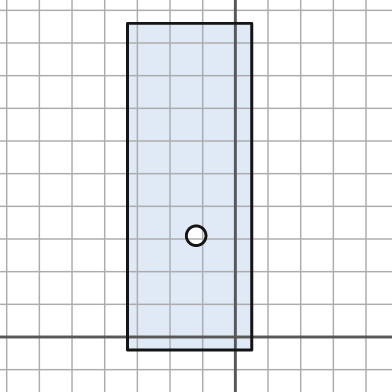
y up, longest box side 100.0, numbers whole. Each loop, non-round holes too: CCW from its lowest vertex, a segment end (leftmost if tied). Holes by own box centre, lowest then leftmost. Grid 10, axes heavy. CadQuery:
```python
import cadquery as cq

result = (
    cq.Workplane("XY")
    .moveTo(-33.0, -4.0)
    .lineTo(5.0, -4.0)
    .lineTo(5.0, 96.0)
    .lineTo(-33.0, 96.0)
    .close()
    .moveTo(-12.0, 31.0)
    .circle(3.0)
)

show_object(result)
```